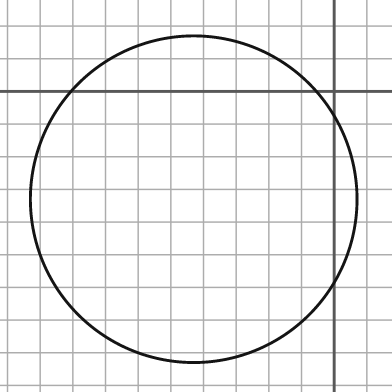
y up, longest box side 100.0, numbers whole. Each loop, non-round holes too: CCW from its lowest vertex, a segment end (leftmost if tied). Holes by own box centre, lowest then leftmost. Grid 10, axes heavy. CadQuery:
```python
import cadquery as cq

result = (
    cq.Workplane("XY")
    .moveTo(-43.0, -33.0)
    .circle(50.0)
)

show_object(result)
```